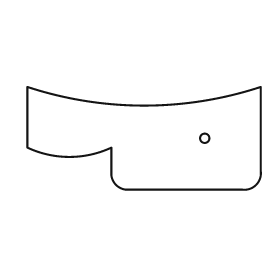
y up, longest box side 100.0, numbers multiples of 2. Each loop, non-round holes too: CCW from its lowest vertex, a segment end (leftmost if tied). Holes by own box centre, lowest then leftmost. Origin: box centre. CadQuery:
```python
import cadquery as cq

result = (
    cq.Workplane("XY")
    .moveTo(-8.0, -22.0)
    .lineTo(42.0, -22.0)
    .threePointArc((48.0, -20.0), (50.0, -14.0))
    .lineTo(50.0, 22.0)
    .threePointArc((0.0, 14.0), (-50.0, 22.0))
    .lineTo(-50.0, -4.0)
    .threePointArc((-32.0, -8.0), (-14.0, -4.0))
    .lineTo(-14.0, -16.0)
    .threePointArc((-12.0, -20.0), (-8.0, -22.0))
    .close()
    .moveTo(26.0, 0.0)
    .circle(2.0)
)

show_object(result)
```